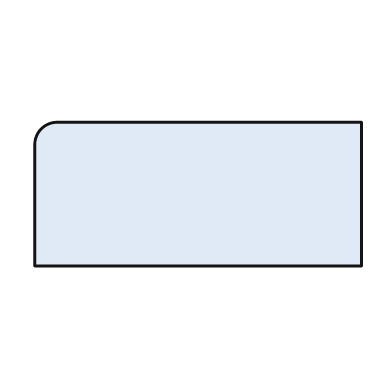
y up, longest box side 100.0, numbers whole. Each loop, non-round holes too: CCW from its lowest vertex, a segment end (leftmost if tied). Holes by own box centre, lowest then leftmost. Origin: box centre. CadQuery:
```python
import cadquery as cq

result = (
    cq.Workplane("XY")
    .moveTo(-50.0, -22.0)
    .lineTo(50.0, -22.0)
    .lineTo(50.0, 22.0)
    .lineTo(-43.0, 22.0)
    .threePointArc((-48.0, 20.0), (-50.0, 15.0))
    .close()
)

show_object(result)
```